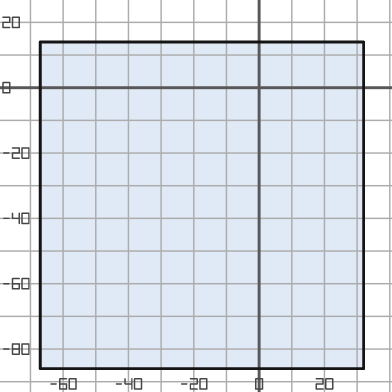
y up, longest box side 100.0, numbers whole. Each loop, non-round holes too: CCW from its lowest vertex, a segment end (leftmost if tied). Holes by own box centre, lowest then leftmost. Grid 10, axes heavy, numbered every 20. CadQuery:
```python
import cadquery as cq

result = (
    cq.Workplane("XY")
    .moveTo(-67.0, -86.0)
    .lineTo(32.0, -86.0)
    .lineTo(32.0, 14.0)
    .lineTo(-67.0, 14.0)
    .close()
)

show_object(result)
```